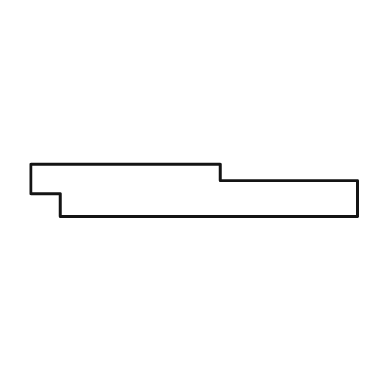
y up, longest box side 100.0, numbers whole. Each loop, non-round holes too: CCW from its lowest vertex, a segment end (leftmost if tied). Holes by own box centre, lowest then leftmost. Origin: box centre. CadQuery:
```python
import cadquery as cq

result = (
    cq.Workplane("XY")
    .moveTo(-41.0, -8.0)
    .lineTo(50.0, -8.0)
    .lineTo(50.0, 3.0)
    .lineTo(8.0, 3.0)
    .lineTo(8.0, 8.0)
    .lineTo(-50.0, 8.0)
    .lineTo(-50.0, -1.0)
    .lineTo(-41.0, -1.0)
    .close()
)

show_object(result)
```